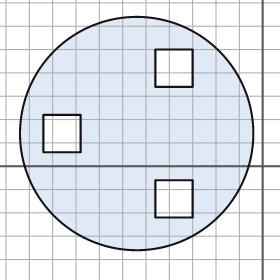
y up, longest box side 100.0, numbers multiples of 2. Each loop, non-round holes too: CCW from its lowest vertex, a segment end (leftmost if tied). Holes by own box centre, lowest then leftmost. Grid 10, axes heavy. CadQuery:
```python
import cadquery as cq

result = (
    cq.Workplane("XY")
    .moveTo(-54.0, 14.0)
    .circle(50.0)
    .moveTo(-46.0, -22.0)
    .lineTo(-30.0, -22.0)
    .lineTo(-30.0, -6.0)
    .lineTo(-46.0, -6.0)
    .close()
    .moveTo(-94.0, 6.0)
    .lineTo(-78.0, 6.0)
    .lineTo(-78.0, 22.0)
    .lineTo(-94.0, 22.0)
    .close()
    .moveTo(-46.0, 34.0)
    .lineTo(-30.0, 34.0)
    .lineTo(-30.0, 50.0)
    .lineTo(-46.0, 50.0)
    .close()
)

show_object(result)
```